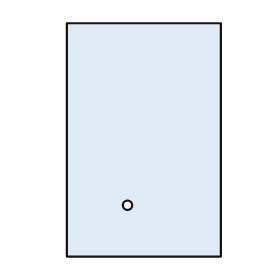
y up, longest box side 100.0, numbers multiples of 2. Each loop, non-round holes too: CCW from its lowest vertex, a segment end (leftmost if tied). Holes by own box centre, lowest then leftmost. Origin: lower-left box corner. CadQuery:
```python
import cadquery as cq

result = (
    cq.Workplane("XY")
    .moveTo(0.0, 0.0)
    .lineTo(66.0, 0.0)
    .lineTo(66.0, 100.0)
    .lineTo(0.0, 100.0)
    .close()
    .moveTo(26.0, 22.0)
    .circle(2.0)
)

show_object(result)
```